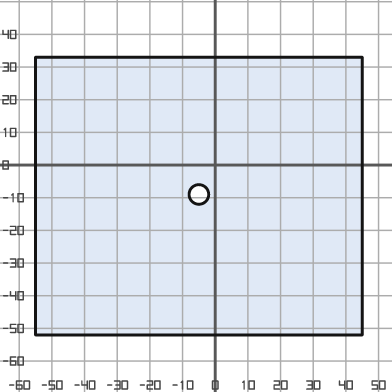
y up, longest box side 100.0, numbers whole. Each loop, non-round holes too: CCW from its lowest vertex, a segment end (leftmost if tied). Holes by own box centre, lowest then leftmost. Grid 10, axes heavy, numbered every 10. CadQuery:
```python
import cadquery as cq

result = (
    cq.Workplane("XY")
    .moveTo(-55.0, -52.0)
    .lineTo(45.0, -52.0)
    .lineTo(45.0, 33.0)
    .lineTo(-55.0, 33.0)
    .close()
    .moveTo(-5.0, -9.0)
    .circle(3.0)
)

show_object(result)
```